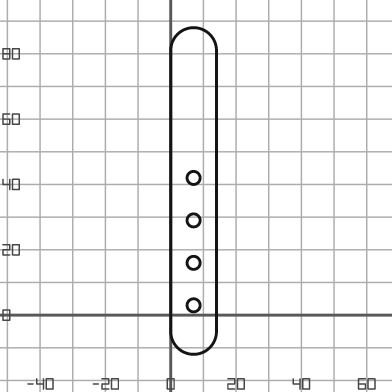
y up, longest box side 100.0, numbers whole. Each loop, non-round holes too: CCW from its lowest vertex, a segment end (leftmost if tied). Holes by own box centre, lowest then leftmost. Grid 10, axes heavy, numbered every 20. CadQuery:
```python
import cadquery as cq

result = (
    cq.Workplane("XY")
    .moveTo(0.0, -5.0)
    .threePointArc((7.0, -12.0), (14.0, -5.0))
    .lineTo(14.0, 81.0)
    .threePointArc((7.0, 88.0), (0.0, 81.0))
    .close()
    .moveTo(7.0, 3.0)
    .circle(2.0)
    .moveTo(7.0, 16.0)
    .circle(2.0)
    .moveTo(7.0, 29.0)
    .circle(2.0)
    .moveTo(7.0, 42.0)
    .circle(2.0)
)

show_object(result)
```